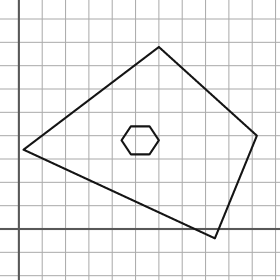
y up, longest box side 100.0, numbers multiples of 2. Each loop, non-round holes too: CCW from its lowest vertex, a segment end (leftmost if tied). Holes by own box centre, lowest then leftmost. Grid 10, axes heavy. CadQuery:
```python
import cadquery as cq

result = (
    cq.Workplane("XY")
    .moveTo(84.0, -4.0)
    .lineTo(102.0, 40.0)
    .lineTo(60.0, 78.0)
    .lineTo(2.0, 34.0)
    .close()
    .moveTo(48.0, 32.0)
    .lineTo(56.0, 32.0)
    .lineTo(60.0, 38.0)
    .lineTo(56.0, 44.0)
    .lineTo(48.0, 44.0)
    .lineTo(44.0, 38.0)
    .close()
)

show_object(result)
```